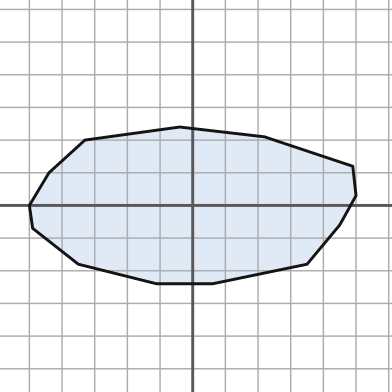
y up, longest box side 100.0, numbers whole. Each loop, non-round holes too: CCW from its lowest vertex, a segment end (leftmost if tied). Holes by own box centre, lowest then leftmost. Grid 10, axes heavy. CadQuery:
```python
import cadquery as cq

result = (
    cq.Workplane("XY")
    .moveTo(-11.0, -24.0)
    .lineTo(6.0, -24.0)
    .lineTo(35.0, -18.0)
    .lineTo(45.0, -6.0)
    .lineTo(50.0, 3.0)
    .lineTo(49.0, 12.0)
    .lineTo(22.0, 21.0)
    .lineTo(-4.0, 24.0)
    .lineTo(-33.0, 20.0)
    .lineTo(-44.0, 10.0)
    .lineTo(-50.0, 0.0)
    .lineTo(-49.0, -7.0)
    .lineTo(-35.0, -18.0)
    .close()
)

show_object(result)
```